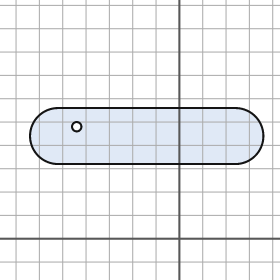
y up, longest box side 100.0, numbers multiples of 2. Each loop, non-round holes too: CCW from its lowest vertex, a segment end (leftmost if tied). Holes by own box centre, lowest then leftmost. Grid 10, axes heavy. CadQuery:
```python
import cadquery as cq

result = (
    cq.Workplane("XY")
    .moveTo(-52.0, 32.0)
    .lineTo(24.0, 32.0)
    .threePointArc((36.0, 44.0), (24.0, 56.0))
    .lineTo(-52.0, 56.0)
    .threePointArc((-64.0, 44.0), (-52.0, 32.0))
    .close()
    .moveTo(-44.0, 48.0)
    .circle(2.0)
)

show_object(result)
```